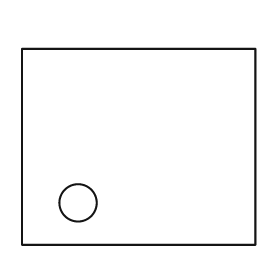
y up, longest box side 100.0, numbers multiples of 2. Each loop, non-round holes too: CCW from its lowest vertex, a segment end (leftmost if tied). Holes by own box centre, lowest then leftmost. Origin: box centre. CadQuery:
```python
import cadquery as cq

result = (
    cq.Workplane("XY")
    .moveTo(-50.0, -42.0)
    .lineTo(50.0, -42.0)
    .lineTo(50.0, 42.0)
    .lineTo(-50.0, 42.0)
    .close()
    .moveTo(-26.0, -24.0)
    .circle(8.0)
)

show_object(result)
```